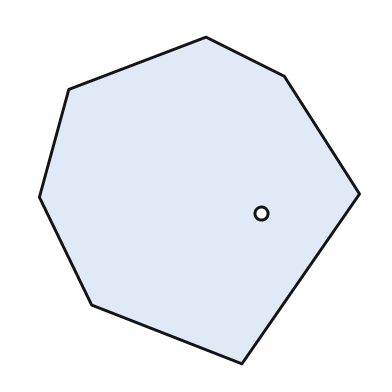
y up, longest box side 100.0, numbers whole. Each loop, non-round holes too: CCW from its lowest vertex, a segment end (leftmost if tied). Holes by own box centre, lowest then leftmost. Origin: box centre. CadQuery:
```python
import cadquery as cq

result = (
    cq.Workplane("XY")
    .moveTo(13.0, -50.0)
    .lineTo(49.0, 2.0)
    .lineTo(26.0, 38.0)
    .lineTo(2.0, 50.0)
    .lineTo(-40.0, 34.0)
    .lineTo(-49.0, 1.0)
    .lineTo(-33.0, -32.0)
    .close()
    .moveTo(19.0, -4.0)
    .circle(2.0)
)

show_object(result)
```